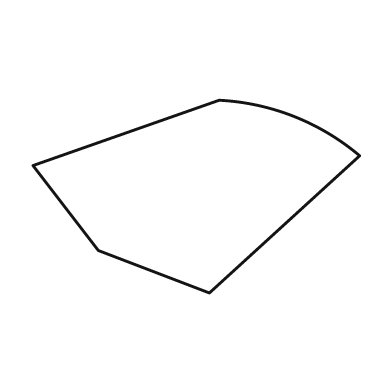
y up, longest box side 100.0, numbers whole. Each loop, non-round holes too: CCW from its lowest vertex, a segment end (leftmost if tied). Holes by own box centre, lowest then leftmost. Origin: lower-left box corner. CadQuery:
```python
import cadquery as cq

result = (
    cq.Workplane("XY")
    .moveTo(54.0, 0.0)
    .lineTo(100.0, 42.0)
    .threePointArc((80.0, 54.0), (57.0, 59.0))
    .lineTo(0.0, 39.0)
    .lineTo(20.0, 13.0)
    .close()
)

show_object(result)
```